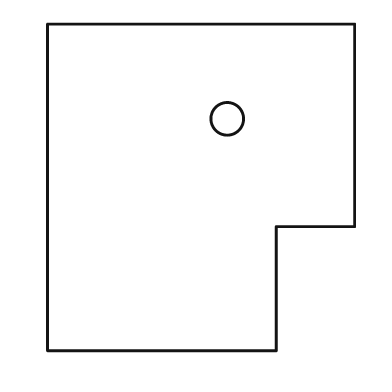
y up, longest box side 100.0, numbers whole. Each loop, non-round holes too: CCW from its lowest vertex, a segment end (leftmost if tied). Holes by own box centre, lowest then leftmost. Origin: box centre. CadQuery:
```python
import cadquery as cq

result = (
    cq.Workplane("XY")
    .moveTo(-47.0, -50.0)
    .lineTo(23.0, -50.0)
    .lineTo(23.0, -12.0)
    .lineTo(47.0, -12.0)
    .lineTo(47.0, 50.0)
    .lineTo(-47.0, 50.0)
    .close()
    .moveTo(8.0, 21.0)
    .circle(5.0)
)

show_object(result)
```